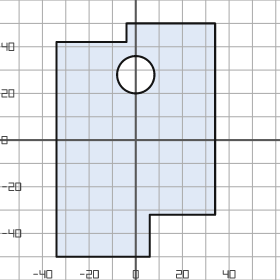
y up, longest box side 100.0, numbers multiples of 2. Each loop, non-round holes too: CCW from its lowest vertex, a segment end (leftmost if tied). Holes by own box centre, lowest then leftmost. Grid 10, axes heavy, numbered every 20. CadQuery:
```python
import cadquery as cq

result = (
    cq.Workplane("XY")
    .moveTo(-34.0, -50.0)
    .lineTo(6.0, -50.0)
    .lineTo(6.0, -32.0)
    .lineTo(34.0, -32.0)
    .lineTo(34.0, 50.0)
    .lineTo(-4.0, 50.0)
    .lineTo(-4.0, 42.0)
    .lineTo(-34.0, 42.0)
    .close()
    .moveTo(0.0, 28.0)
    .circle(8.0)
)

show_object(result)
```